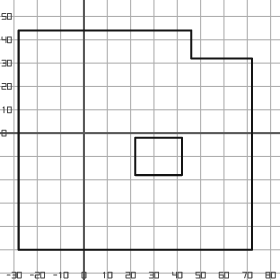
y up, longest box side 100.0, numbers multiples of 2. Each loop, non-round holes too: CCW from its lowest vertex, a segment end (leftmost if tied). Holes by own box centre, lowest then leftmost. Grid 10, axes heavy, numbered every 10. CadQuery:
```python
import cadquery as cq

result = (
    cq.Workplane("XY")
    .moveTo(-28.0, -50.0)
    .lineTo(72.0, -50.0)
    .lineTo(72.0, 32.0)
    .lineTo(46.0, 32.0)
    .lineTo(46.0, 44.0)
    .lineTo(-28.0, 44.0)
    .close()
    .moveTo(22.0, -18.0)
    .lineTo(42.0, -18.0)
    .lineTo(42.0, -2.0)
    .lineTo(22.0, -2.0)
    .close()
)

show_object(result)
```